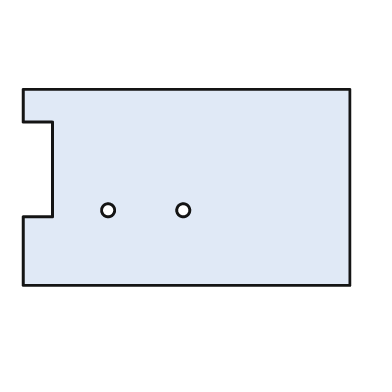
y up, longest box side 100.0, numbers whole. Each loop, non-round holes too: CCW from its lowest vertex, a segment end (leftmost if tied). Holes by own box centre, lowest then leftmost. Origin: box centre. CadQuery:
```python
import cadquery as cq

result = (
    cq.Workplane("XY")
    .moveTo(-50.0, -30.0)
    .lineTo(50.0, -30.0)
    .lineTo(50.0, 30.0)
    .lineTo(-50.0, 30.0)
    .lineTo(-50.0, 20.0)
    .lineTo(-41.0, 20.0)
    .lineTo(-41.0, -9.0)
    .lineTo(-50.0, -9.0)
    .close()
    .moveTo(-24.0, -7.0)
    .circle(2.0)
    .moveTo(-1.0, -7.0)
    .circle(2.0)
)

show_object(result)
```